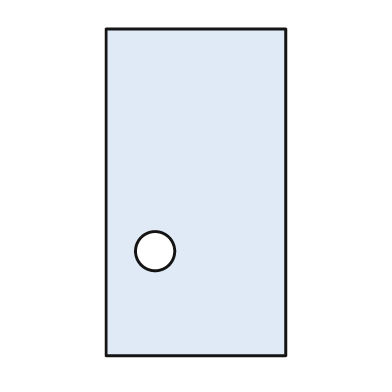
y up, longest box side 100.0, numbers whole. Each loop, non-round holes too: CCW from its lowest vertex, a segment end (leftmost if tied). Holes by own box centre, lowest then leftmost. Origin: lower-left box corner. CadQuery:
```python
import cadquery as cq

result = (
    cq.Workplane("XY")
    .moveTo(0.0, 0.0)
    .lineTo(55.0, 0.0)
    .lineTo(55.0, 100.0)
    .lineTo(0.0, 100.0)
    .close()
    .moveTo(15.0, 32.0)
    .circle(6.0)
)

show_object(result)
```